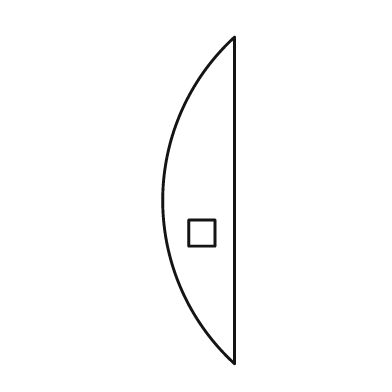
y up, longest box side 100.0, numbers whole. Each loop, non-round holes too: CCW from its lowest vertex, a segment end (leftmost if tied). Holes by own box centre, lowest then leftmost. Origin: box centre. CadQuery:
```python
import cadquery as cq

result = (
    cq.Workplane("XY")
    .moveTo(11.0, -50.0)
    .lineTo(11.0, 50.0)
    .threePointArc((-11.0, 0.0), (11.0, -50.0))
    .close()
    .moveTo(-3.0, -14.0)
    .lineTo(5.0, -14.0)
    .lineTo(5.0, -6.0)
    .lineTo(-3.0, -6.0)
    .close()
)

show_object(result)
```